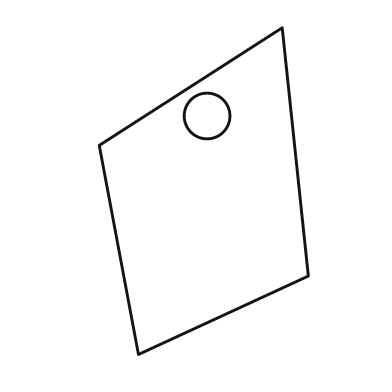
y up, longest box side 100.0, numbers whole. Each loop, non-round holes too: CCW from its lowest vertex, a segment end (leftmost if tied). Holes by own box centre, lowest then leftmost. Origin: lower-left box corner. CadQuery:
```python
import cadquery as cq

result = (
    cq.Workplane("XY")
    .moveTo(12.0, 0.0)
    .lineTo(64.0, 24.0)
    .lineTo(56.0, 100.0)
    .lineTo(0.0, 64.0)
    .close()
    .moveTo(33.0, 73.0)
    .circle(7.0)
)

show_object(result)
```